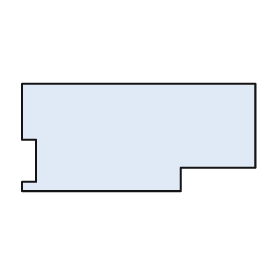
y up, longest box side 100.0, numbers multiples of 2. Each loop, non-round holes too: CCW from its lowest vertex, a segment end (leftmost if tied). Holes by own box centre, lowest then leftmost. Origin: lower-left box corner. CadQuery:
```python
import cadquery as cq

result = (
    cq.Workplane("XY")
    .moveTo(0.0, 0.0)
    .lineTo(68.0, 0.0)
    .lineTo(68.0, 10.0)
    .lineTo(100.0, 10.0)
    .lineTo(100.0, 46.0)
    .lineTo(0.0, 46.0)
    .lineTo(0.0, 22.0)
    .lineTo(6.0, 22.0)
    .lineTo(6.0, 4.0)
    .lineTo(0.0, 4.0)
    .close()
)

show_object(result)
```